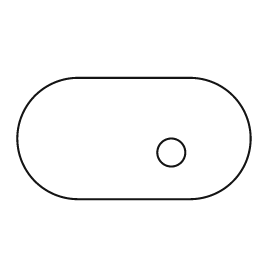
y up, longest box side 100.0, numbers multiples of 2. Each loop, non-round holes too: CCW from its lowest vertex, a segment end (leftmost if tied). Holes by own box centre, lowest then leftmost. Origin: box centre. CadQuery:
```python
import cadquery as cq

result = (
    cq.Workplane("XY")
    .moveTo(-24.0, -26.0)
    .lineTo(24.0, -26.0)
    .threePointArc((50.0, 0.0), (24.0, 26.0))
    .lineTo(-24.0, 26.0)
    .threePointArc((-50.0, 0.0), (-24.0, -26.0))
    .close()
    .moveTo(16.0, -6.0)
    .circle(6.0)
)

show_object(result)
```